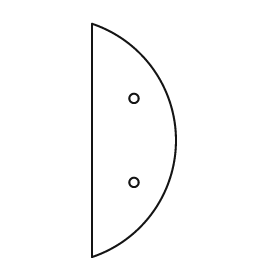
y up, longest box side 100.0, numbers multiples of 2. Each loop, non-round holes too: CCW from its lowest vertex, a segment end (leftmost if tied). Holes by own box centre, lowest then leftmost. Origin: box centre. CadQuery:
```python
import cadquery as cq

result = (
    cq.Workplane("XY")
    .moveTo(-18.0, -50.0)
    .threePointArc((18.0, 0.0), (-18.0, 50.0))
    .close()
    .moveTo(0.0, -18.0)
    .circle(2.0)
    .moveTo(0.0, 18.0)
    .circle(2.0)
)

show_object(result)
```